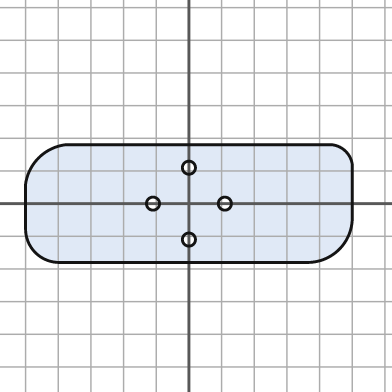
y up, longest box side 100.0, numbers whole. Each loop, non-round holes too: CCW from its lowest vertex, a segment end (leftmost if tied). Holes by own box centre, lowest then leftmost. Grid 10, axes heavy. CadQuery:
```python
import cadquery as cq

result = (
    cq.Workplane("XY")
    .moveTo(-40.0, -18.0)
    .lineTo(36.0, -18.0)
    .threePointArc((46.0, -14.0), (50.0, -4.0))
    .lineTo(50.0, 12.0)
    .threePointArc((48.0, 16.0), (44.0, 18.0))
    .lineTo(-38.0, 18.0)
    .threePointArc((-46.0, 14.0), (-50.0, 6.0))
    .lineTo(-50.0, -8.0)
    .threePointArc((-47.0, -15.0), (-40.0, -18.0))
    .close()
    .moveTo(0.0, -11.0)
    .circle(2.0)
    .moveTo(-11.0, 0.0)
    .circle(2.0)
    .moveTo(11.0, 0.0)
    .circle(2.0)
    .moveTo(0.0, 11.0)
    .circle(2.0)
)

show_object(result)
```